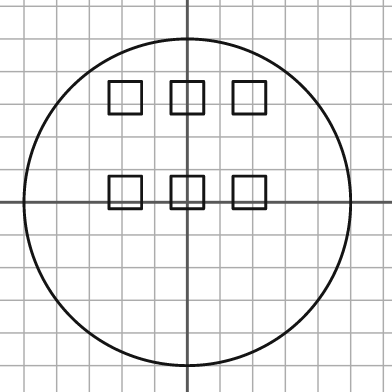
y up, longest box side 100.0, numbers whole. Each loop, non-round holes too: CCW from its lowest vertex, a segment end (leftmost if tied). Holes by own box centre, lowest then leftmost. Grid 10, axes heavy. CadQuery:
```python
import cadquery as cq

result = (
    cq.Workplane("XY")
    .moveTo(0.0, 0.0)
    .circle(50.0)
    .moveTo(-24.0, -2.0)
    .lineTo(-14.0, -2.0)
    .lineTo(-14.0, 8.0)
    .lineTo(-24.0, 8.0)
    .close()
    .moveTo(-5.0, -2.0)
    .lineTo(5.0, -2.0)
    .lineTo(5.0, 8.0)
    .lineTo(-5.0, 8.0)
    .close()
    .moveTo(14.0, -2.0)
    .lineTo(24.0, -2.0)
    .lineTo(24.0, 8.0)
    .lineTo(14.0, 8.0)
    .close()
    .moveTo(-24.0, 27.0)
    .lineTo(-14.0, 27.0)
    .lineTo(-14.0, 37.0)
    .lineTo(-24.0, 37.0)
    .close()
    .moveTo(-5.0, 27.0)
    .lineTo(5.0, 27.0)
    .lineTo(5.0, 37.0)
    .lineTo(-5.0, 37.0)
    .close()
    .moveTo(14.0, 27.0)
    .lineTo(24.0, 27.0)
    .lineTo(24.0, 37.0)
    .lineTo(14.0, 37.0)
    .close()
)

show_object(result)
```